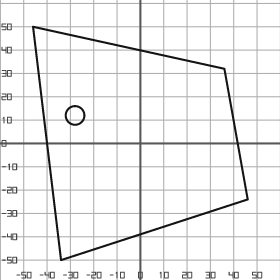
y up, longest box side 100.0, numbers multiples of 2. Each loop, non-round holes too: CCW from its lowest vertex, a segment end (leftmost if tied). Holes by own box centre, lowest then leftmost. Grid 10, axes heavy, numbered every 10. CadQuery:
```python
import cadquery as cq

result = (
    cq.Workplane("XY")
    .moveTo(-34.0, -50.0)
    .lineTo(46.0, -24.0)
    .lineTo(36.0, 32.0)
    .lineTo(-46.0, 50.0)
    .close()
    .moveTo(-28.0, 12.0)
    .circle(4.0)
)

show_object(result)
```